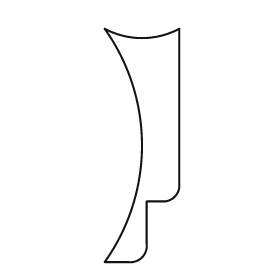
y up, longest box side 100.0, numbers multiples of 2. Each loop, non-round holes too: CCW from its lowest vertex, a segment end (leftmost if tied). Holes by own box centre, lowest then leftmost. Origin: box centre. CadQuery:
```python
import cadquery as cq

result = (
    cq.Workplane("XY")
    .moveTo(-16.0, -50.0)
    .lineTo(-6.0, -50.0)
    .threePointArc((0.0, -48.0), (2.0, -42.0))
    .lineTo(2.0, -24.0)
    .lineTo(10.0, -24.0)
    .threePointArc((14.0, -22.0), (16.0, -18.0))
    .lineTo(16.0, 50.0)
    .threePointArc((0.0, 46.0), (-16.0, 50.0))
    .threePointArc((0.0, 0.0), (-16.0, -50.0))
    .close()
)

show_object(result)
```